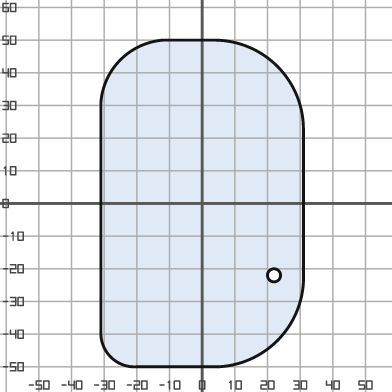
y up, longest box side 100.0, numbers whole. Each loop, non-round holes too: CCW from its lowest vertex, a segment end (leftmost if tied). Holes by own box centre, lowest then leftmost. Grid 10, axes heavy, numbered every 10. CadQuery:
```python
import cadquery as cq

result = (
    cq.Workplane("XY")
    .moveTo(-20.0, -50.0)
    .lineTo(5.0, -50.0)
    .threePointArc((23.0, -42.0), (31.0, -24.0))
    .lineTo(31.0, 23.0)
    .threePointArc((23.0, 42.0), (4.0, 50.0))
    .lineTo(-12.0, 50.0)
    .threePointArc((-25.0, 44.0), (-31.0, 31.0))
    .lineTo(-31.0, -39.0)
    .threePointArc((-28.0, -47.0), (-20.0, -50.0))
    .close()
    .moveTo(22.0, -22.0)
    .circle(2.0)
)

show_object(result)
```